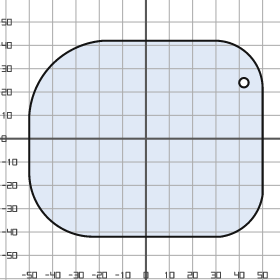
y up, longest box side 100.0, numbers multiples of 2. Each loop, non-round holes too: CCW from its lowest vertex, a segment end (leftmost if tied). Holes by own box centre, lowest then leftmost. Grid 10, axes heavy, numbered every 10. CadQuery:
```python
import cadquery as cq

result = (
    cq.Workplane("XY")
    .moveTo(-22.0, -42.0)
    .lineTo(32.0, -42.0)
    .threePointArc((44.0, -36.0), (50.0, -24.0))
    .lineTo(50.0, 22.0)
    .threePointArc((44.0, 36.0), (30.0, 42.0))
    .lineTo(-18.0, 42.0)
    .threePointArc((-40.0, 32.0), (-50.0, 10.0))
    .lineTo(-50.0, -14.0)
    .threePointArc((-42.0, -34.0), (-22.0, -42.0))
    .close()
    .moveTo(42.0, 24.0)
    .circle(2.0)
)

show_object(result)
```